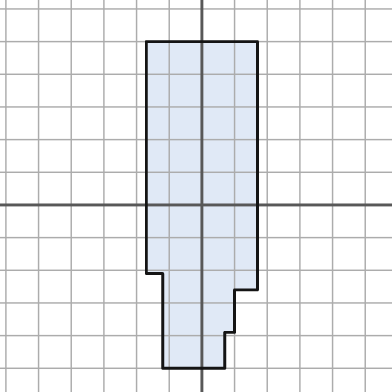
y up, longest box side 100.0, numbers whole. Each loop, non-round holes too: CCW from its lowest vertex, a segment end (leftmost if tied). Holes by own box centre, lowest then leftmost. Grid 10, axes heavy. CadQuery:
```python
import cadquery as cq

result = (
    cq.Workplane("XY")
    .moveTo(-12.0, -50.0)
    .lineTo(7.0, -50.0)
    .lineTo(7.0, -39.0)
    .lineTo(10.0, -39.0)
    .lineTo(10.0, -26.0)
    .lineTo(17.0, -26.0)
    .lineTo(17.0, 50.0)
    .lineTo(-17.0, 50.0)
    .lineTo(-17.0, -21.0)
    .lineTo(-12.0, -21.0)
    .close()
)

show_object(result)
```